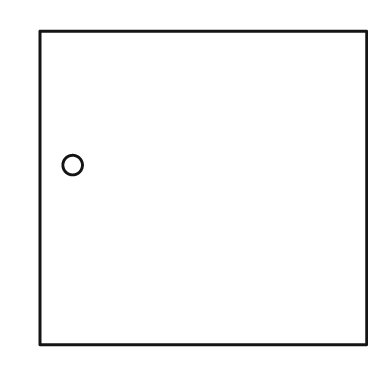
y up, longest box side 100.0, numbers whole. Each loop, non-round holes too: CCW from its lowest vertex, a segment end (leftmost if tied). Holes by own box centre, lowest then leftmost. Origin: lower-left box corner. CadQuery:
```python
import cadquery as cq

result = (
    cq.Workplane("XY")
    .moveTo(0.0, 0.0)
    .lineTo(100.0, 0.0)
    .lineTo(100.0, 96.0)
    .lineTo(0.0, 96.0)
    .close()
    .moveTo(10.0, 55.0)
    .circle(3.0)
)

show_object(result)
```